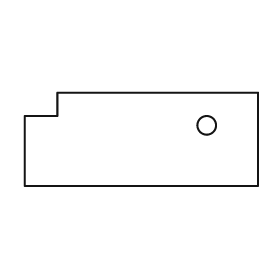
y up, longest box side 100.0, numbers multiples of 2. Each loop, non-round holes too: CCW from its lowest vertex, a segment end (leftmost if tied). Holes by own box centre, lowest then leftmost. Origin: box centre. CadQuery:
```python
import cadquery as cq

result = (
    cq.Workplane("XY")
    .moveTo(-50.0, -20.0)
    .lineTo(50.0, -20.0)
    .lineTo(50.0, 20.0)
    .lineTo(-36.0, 20.0)
    .lineTo(-36.0, 10.0)
    .lineTo(-50.0, 10.0)
    .close()
    .moveTo(28.0, 6.0)
    .circle(4.0)
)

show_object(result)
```